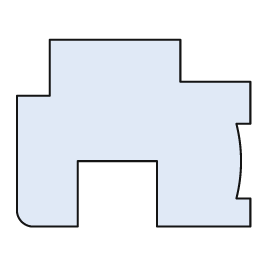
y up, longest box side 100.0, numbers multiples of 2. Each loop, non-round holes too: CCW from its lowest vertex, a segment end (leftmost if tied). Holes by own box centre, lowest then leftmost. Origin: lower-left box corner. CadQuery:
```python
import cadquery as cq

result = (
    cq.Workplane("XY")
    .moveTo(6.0, 0.0)
    .lineTo(26.0, 0.0)
    .lineTo(26.0, 28.0)
    .lineTo(60.0, 28.0)
    .lineTo(60.0, 0.0)
    .lineTo(100.0, 0.0)
    .lineTo(100.0, 12.0)
    .lineTo(94.0, 12.0)
    .threePointArc((96.0, 28.0), (94.0, 44.0))
    .lineTo(100.0, 44.0)
    .lineTo(100.0, 62.0)
    .lineTo(70.0, 62.0)
    .lineTo(70.0, 80.0)
    .lineTo(14.0, 80.0)
    .lineTo(14.0, 56.0)
    .lineTo(0.0, 56.0)
    .lineTo(0.0, 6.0)
    .threePointArc((2.0, 2.0), (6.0, 0.0))
    .close()
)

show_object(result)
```